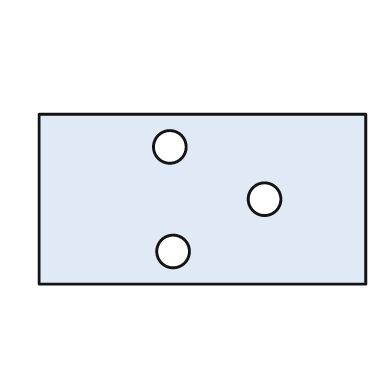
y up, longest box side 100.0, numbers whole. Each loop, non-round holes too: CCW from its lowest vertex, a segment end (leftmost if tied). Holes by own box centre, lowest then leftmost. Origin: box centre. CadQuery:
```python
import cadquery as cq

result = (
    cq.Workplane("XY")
    .moveTo(-50.0, -26.0)
    .lineTo(50.0, -26.0)
    .lineTo(50.0, 26.0)
    .lineTo(-50.0, 26.0)
    .close()
    .moveTo(-9.0, -16.0)
    .circle(5.0)
    .moveTo(19.0, 0.0)
    .circle(5.0)
    .moveTo(-10.0, 16.0)
    .circle(5.0)
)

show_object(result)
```